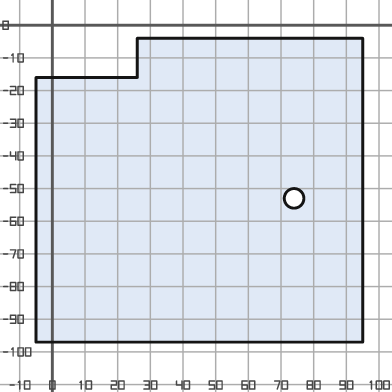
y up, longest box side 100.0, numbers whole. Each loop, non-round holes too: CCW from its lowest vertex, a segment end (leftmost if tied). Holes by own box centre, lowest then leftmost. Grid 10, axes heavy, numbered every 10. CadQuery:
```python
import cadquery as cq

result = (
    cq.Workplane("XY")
    .moveTo(-5.0, -97.0)
    .lineTo(95.0, -97.0)
    .lineTo(95.0, -4.0)
    .lineTo(26.0, -4.0)
    .lineTo(26.0, -16.0)
    .lineTo(-5.0, -16.0)
    .close()
    .moveTo(74.0, -53.0)
    .circle(3.0)
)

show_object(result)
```